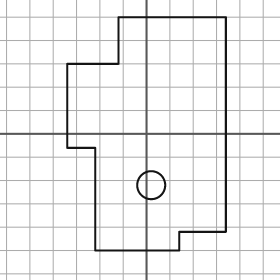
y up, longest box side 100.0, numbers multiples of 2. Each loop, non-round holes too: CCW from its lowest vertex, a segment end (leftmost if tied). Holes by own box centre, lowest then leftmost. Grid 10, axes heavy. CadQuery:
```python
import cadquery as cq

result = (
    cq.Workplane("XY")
    .moveTo(-22.0, -50.0)
    .lineTo(14.0, -50.0)
    .lineTo(14.0, -42.0)
    .lineTo(34.0, -42.0)
    .lineTo(34.0, 50.0)
    .lineTo(-12.0, 50.0)
    .lineTo(-12.0, 30.0)
    .lineTo(-34.0, 30.0)
    .lineTo(-34.0, -6.0)
    .lineTo(-22.0, -6.0)
    .close()
    .moveTo(2.0, -22.0)
    .circle(6.0)
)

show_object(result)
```